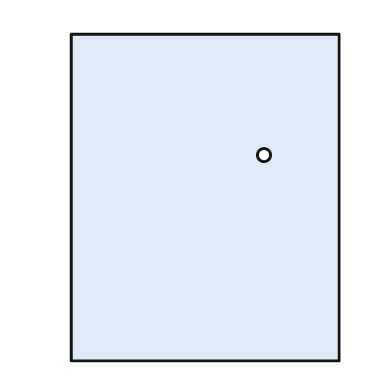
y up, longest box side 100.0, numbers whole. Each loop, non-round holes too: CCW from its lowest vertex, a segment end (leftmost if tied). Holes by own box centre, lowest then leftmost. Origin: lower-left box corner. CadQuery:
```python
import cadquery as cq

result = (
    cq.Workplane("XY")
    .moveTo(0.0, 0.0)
    .lineTo(82.0, 0.0)
    .lineTo(82.0, 100.0)
    .lineTo(0.0, 100.0)
    .close()
    .moveTo(59.0, 63.0)
    .circle(2.0)
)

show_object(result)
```